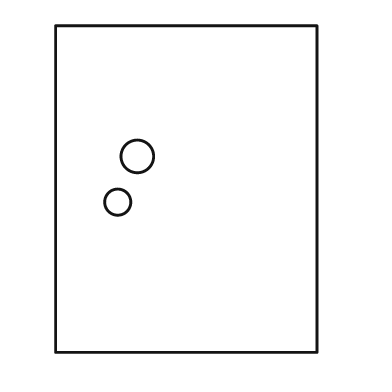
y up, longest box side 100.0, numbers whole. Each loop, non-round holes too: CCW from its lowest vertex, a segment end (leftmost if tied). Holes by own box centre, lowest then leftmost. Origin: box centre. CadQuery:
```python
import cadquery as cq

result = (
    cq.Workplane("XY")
    .moveTo(-40.0, -50.0)
    .lineTo(40.0, -50.0)
    .lineTo(40.0, 50.0)
    .lineTo(-40.0, 50.0)
    .close()
    .moveTo(-21.0, -4.0)
    .circle(4.0)
    .moveTo(-15.0, 10.0)
    .circle(5.0)
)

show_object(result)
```